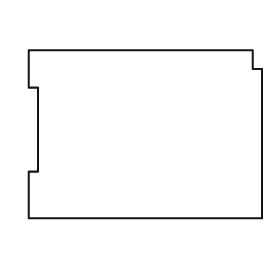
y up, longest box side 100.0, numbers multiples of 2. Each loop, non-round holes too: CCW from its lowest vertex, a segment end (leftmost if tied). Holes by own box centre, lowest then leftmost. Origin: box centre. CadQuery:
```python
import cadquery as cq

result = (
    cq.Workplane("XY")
    .moveTo(-50.0, -36.0)
    .lineTo(50.0, -36.0)
    .lineTo(50.0, 28.0)
    .lineTo(46.0, 28.0)
    .lineTo(46.0, 36.0)
    .lineTo(-50.0, 36.0)
    .lineTo(-50.0, 20.0)
    .lineTo(-46.0, 20.0)
    .lineTo(-46.0, -16.0)
    .lineTo(-50.0, -16.0)
    .close()
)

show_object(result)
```